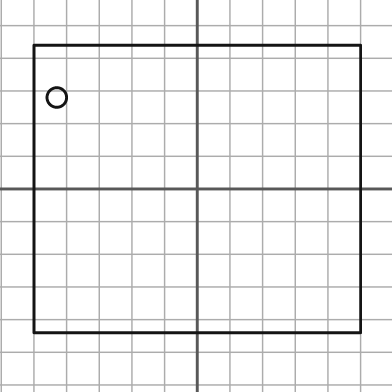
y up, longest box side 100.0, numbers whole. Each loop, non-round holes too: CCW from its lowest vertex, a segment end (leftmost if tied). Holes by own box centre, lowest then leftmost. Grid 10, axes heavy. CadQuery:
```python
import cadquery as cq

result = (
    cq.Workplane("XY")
    .moveTo(-50.0, -44.0)
    .lineTo(50.0, -44.0)
    .lineTo(50.0, 44.0)
    .lineTo(-50.0, 44.0)
    .close()
    .moveTo(-43.0, 28.0)
    .circle(3.0)
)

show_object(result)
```